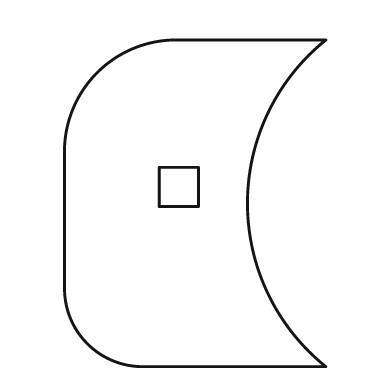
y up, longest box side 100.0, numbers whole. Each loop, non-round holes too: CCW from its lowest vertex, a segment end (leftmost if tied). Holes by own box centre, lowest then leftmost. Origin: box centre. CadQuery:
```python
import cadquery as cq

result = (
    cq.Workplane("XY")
    .moveTo(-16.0, -50.0)
    .lineTo(40.0, -50.0)
    .threePointArc((16.0, 0.0), (40.0, 50.0))
    .lineTo(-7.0, 50.0)
    .threePointArc((-30.0, 40.0), (-40.0, 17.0))
    .lineTo(-40.0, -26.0)
    .threePointArc((-33.0, -43.0), (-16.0, -50.0))
    .close()
    .moveTo(-11.0, -1.0)
    .lineTo(1.0, -1.0)
    .lineTo(1.0, 11.0)
    .lineTo(-11.0, 11.0)
    .close()
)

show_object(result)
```